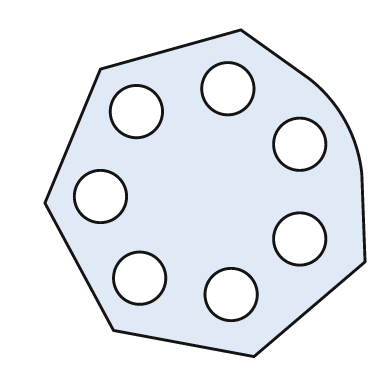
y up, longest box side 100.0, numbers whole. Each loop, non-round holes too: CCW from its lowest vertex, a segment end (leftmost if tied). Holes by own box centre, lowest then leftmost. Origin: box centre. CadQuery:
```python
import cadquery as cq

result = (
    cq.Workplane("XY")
    .moveTo(15.0, -50.0)
    .lineTo(49.0, -21.0)
    .lineTo(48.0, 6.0)
    .threePointArc((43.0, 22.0), (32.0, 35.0))
    .lineTo(11.0, 50.0)
    .lineTo(-32.0, 38.0)
    .lineTo(-49.0, -3.0)
    .lineTo(-28.0, -42.0)
    .close()
    .moveTo(8.0, -31.0)
    .circle(8.0)
    .moveTo(-20.0, -26.0)
    .circle(8.0)
    .moveTo(29.0, -14.0)
    .circle(8.0)
    .moveTo(-32.0, -1.0)
    .circle(8.0)
    .moveTo(29.0, 15.0)
    .circle(8.0)
    .moveTo(-21.0, 25.0)
    .circle(8.0)
    .moveTo(7.0, 32.0)
    .circle(8.0)
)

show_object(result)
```